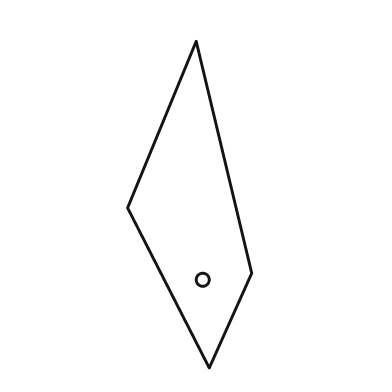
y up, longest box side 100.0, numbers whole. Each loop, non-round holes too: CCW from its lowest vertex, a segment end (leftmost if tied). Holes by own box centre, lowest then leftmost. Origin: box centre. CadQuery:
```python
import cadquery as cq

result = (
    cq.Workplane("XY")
    .moveTo(6.0, -50.0)
    .lineTo(19.0, -21.0)
    .lineTo(2.0, 50.0)
    .lineTo(-19.0, -1.0)
    .close()
    .moveTo(4.0, -23.0)
    .circle(2.0)
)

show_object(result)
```